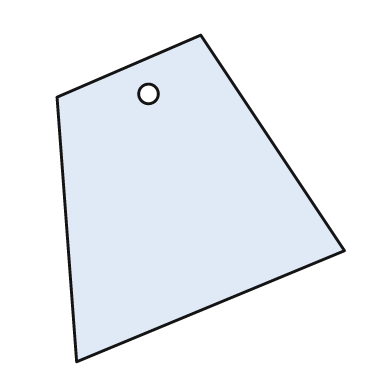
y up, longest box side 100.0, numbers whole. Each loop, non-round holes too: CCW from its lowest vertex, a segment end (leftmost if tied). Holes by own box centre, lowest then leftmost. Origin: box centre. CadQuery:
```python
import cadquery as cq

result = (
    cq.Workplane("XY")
    .moveTo(-38.0, -50.0)
    .lineTo(44.0, -16.0)
    .lineTo(0.0, 50.0)
    .lineTo(-44.0, 31.0)
    .close()
    .moveTo(-16.0, 32.0)
    .circle(3.0)
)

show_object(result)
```